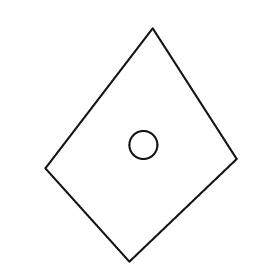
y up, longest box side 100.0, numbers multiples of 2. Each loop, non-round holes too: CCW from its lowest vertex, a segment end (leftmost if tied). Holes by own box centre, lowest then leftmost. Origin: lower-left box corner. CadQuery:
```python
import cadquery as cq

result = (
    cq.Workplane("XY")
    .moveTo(36.0, 0.0)
    .lineTo(82.0, 44.0)
    .lineTo(46.0, 100.0)
    .lineTo(0.0, 40.0)
    .close()
    .moveTo(42.0, 50.0)
    .circle(6.0)
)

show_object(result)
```